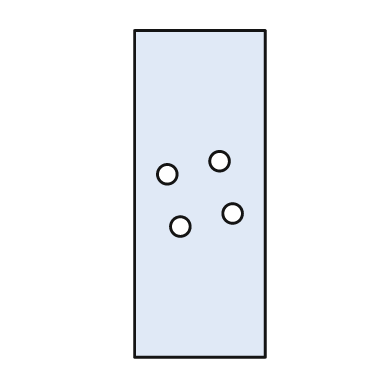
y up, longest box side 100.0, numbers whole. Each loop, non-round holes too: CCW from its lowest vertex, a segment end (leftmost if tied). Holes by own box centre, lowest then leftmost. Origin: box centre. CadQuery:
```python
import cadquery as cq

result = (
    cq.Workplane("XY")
    .moveTo(-20.0, -50.0)
    .lineTo(20.0, -50.0)
    .lineTo(20.0, 50.0)
    .lineTo(-20.0, 50.0)
    .close()
    .moveTo(-6.0, -10.0)
    .circle(3.0)
    .moveTo(10.0, -6.0)
    .circle(3.0)
    .moveTo(-10.0, 6.0)
    .circle(3.0)
    .moveTo(6.0, 10.0)
    .circle(3.0)
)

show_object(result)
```